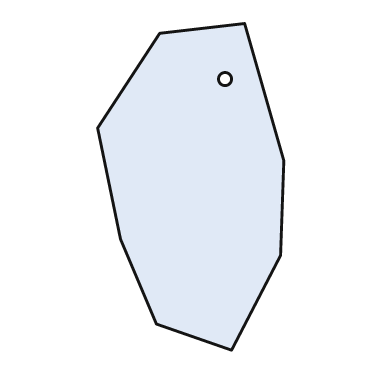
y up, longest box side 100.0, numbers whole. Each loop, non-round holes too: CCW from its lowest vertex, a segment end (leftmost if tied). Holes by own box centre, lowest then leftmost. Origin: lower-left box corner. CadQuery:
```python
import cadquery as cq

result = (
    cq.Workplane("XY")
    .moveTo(41.0, 0.0)
    .lineTo(56.0, 29.0)
    .lineTo(57.0, 58.0)
    .lineTo(45.0, 100.0)
    .lineTo(19.0, 97.0)
    .lineTo(0.0, 68.0)
    .lineTo(7.0, 34.0)
    .lineTo(18.0, 8.0)
    .close()
    .moveTo(39.0, 83.0)
    .circle(2.0)
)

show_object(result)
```